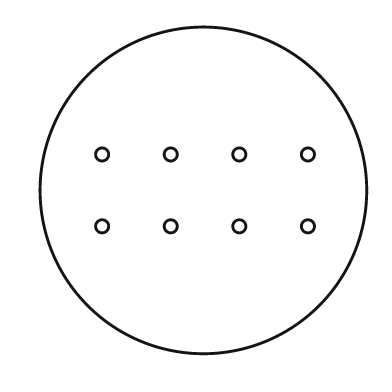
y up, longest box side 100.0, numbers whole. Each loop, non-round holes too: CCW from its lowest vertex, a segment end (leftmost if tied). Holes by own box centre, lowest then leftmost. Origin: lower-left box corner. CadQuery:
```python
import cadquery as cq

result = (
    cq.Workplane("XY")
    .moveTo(50.0, 50.0)
    .circle(50.0)
    .moveTo(19.0, 39.0)
    .circle(2.0)
    .moveTo(40.0, 39.0)
    .circle(2.0)
    .moveTo(61.0, 39.0)
    .circle(2.0)
    .moveTo(82.0, 39.0)
    .circle(2.0)
    .moveTo(19.0, 61.0)
    .circle(2.0)
    .moveTo(40.0, 61.0)
    .circle(2.0)
    .moveTo(61.0, 61.0)
    .circle(2.0)
    .moveTo(82.0, 61.0)
    .circle(2.0)
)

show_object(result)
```